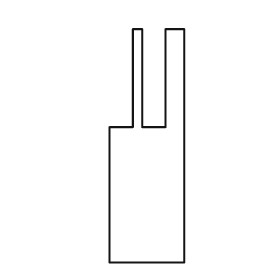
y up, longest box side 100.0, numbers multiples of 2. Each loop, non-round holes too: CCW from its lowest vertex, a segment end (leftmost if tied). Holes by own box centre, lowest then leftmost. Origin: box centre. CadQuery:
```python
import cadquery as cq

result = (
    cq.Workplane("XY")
    .moveTo(-16.0, -50.0)
    .lineTo(16.0, -50.0)
    .lineTo(16.0, 50.0)
    .lineTo(8.0, 50.0)
    .lineTo(8.0, 8.0)
    .lineTo(-2.0, 8.0)
    .lineTo(-2.0, 50.0)
    .lineTo(-6.0, 50.0)
    .lineTo(-6.0, 8.0)
    .lineTo(-16.0, 8.0)
    .close()
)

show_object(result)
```